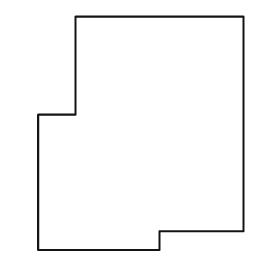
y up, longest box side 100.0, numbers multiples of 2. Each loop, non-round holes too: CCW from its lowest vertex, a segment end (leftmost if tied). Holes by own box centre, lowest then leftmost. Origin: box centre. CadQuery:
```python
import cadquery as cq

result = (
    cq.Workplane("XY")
    .moveTo(-44.0, -50.0)
    .lineTo(8.0, -50.0)
    .lineTo(8.0, -42.0)
    .lineTo(44.0, -42.0)
    .lineTo(44.0, 50.0)
    .lineTo(-28.0, 50.0)
    .lineTo(-28.0, 8.0)
    .lineTo(-44.0, 8.0)
    .close()
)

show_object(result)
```